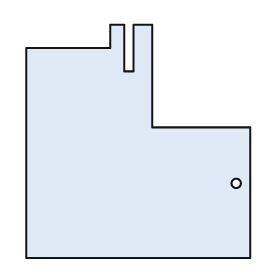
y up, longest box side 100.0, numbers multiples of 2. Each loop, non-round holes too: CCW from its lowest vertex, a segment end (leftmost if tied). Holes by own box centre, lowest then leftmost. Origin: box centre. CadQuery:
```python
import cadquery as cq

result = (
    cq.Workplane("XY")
    .moveTo(-48.0, -50.0)
    .lineTo(48.0, -50.0)
    .lineTo(48.0, 6.0)
    .lineTo(6.0, 6.0)
    .lineTo(6.0, 50.0)
    .lineTo(-2.0, 50.0)
    .lineTo(-2.0, 30.0)
    .lineTo(-6.0, 30.0)
    .lineTo(-6.0, 50.0)
    .lineTo(-12.0, 50.0)
    .lineTo(-12.0, 40.0)
    .lineTo(-48.0, 40.0)
    .close()
    .moveTo(42.0, -18.0)
    .circle(2.0)
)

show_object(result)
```